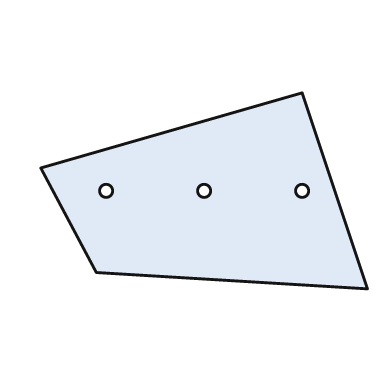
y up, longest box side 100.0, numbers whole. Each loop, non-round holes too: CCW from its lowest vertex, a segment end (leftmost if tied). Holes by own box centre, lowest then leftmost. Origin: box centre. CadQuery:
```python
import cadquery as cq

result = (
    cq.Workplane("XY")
    .moveTo(50.0, -30.0)
    .lineTo(30.0, 30.0)
    .lineTo(-50.0, 7.0)
    .lineTo(-33.0, -25.0)
    .close()
    .moveTo(-30.0, 0.0)
    .circle(2.0)
    .moveTo(0.0, 0.0)
    .circle(2.0)
    .moveTo(30.0, 0.0)
    .circle(2.0)
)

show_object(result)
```